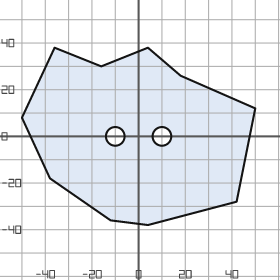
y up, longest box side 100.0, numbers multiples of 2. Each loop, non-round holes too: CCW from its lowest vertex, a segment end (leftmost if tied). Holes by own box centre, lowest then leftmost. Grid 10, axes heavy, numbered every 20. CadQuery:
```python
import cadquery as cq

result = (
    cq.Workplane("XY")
    .moveTo(4.0, -38.0)
    .lineTo(42.0, -28.0)
    .lineTo(50.0, 12.0)
    .lineTo(18.0, 26.0)
    .lineTo(4.0, 38.0)
    .lineTo(-16.0, 30.0)
    .lineTo(-36.0, 38.0)
    .lineTo(-50.0, 8.0)
    .lineTo(-38.0, -18.0)
    .lineTo(-12.0, -36.0)
    .close()
    .moveTo(-10.0, 0.0)
    .circle(4.0)
    .moveTo(10.0, 0.0)
    .circle(4.0)
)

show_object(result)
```